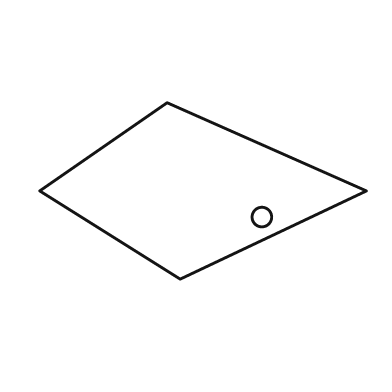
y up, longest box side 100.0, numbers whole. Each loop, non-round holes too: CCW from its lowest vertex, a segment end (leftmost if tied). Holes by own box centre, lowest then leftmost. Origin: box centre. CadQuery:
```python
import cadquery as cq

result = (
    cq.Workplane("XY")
    .moveTo(-7.0, -27.0)
    .lineTo(50.0, 0.0)
    .lineTo(-11.0, 27.0)
    .lineTo(-50.0, 0.0)
    .close()
    .moveTo(18.0, -8.0)
    .circle(3.0)
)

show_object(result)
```